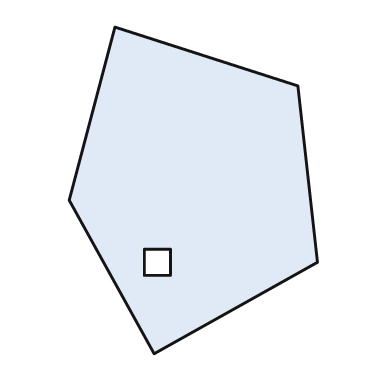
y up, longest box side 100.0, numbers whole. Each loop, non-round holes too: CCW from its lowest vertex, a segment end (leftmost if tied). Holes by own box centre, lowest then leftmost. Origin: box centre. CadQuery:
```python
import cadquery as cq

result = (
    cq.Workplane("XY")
    .moveTo(-12.0, -50.0)
    .lineTo(38.0, -22.0)
    .lineTo(32.0, 32.0)
    .lineTo(-24.0, 50.0)
    .lineTo(-38.0, -3.0)
    .close()
    .moveTo(-15.0, -26.0)
    .lineTo(-7.0, -26.0)
    .lineTo(-7.0, -18.0)
    .lineTo(-15.0, -18.0)
    .close()
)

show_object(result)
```